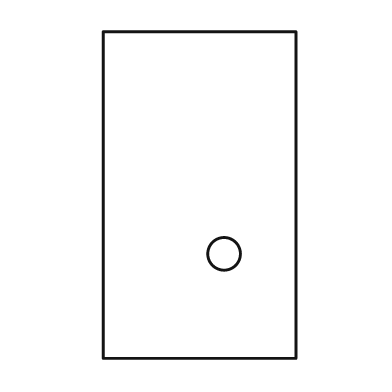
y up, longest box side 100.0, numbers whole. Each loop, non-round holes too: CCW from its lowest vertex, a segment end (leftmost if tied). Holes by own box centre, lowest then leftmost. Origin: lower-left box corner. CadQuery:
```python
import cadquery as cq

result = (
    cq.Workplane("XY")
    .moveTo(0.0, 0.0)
    .lineTo(59.0, 0.0)
    .lineTo(59.0, 100.0)
    .lineTo(0.0, 100.0)
    .close()
    .moveTo(37.0, 32.0)
    .circle(5.0)
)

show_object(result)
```